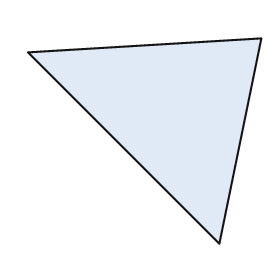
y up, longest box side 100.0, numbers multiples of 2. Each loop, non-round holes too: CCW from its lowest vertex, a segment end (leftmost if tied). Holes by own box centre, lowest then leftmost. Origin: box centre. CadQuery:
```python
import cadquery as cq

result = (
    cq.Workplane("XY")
    .moveTo(32.0, -44.0)
    .lineTo(50.0, 44.0)
    .lineTo(-50.0, 38.0)
    .close()
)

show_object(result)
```